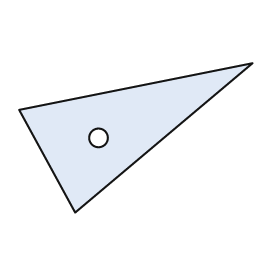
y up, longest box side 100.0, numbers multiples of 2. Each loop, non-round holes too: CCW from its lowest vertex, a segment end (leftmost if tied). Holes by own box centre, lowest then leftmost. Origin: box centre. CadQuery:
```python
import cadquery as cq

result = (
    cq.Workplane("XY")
    .moveTo(-26.0, -32.0)
    .lineTo(50.0, 32.0)
    .lineTo(-50.0, 12.0)
    .close()
    .moveTo(-16.0, 0.0)
    .circle(4.0)
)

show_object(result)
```